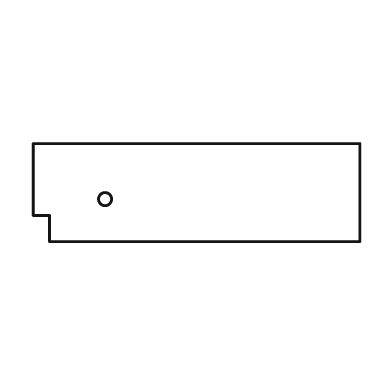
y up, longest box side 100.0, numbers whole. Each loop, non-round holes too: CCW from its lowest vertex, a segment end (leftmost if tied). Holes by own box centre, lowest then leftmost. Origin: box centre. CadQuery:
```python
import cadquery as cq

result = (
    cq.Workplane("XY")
    .moveTo(-45.0, -15.0)
    .lineTo(50.0, -15.0)
    .lineTo(50.0, 15.0)
    .lineTo(-50.0, 15.0)
    .lineTo(-50.0, -7.0)
    .lineTo(-45.0, -7.0)
    .close()
    .moveTo(-28.0, -2.0)
    .circle(2.0)
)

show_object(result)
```